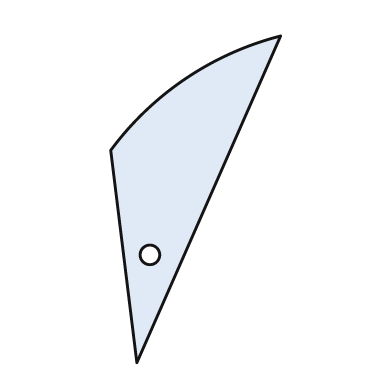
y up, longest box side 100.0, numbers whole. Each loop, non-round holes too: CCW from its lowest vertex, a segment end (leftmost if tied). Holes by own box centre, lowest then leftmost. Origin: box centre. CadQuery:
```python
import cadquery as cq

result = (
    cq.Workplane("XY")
    .moveTo(-18.0, -50.0)
    .lineTo(26.0, 50.0)
    .threePointArc((-3.0, 37.0), (-26.0, 15.0))
    .close()
    .moveTo(-14.0, -17.0)
    .circle(3.0)
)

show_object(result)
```